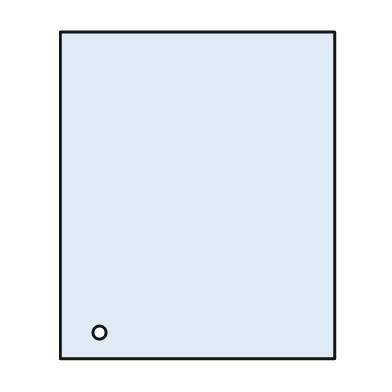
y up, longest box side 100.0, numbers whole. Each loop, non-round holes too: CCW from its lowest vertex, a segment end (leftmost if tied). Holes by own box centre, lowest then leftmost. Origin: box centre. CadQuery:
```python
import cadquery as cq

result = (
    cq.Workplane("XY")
    .moveTo(-42.0, -50.0)
    .lineTo(42.0, -50.0)
    .lineTo(42.0, 50.0)
    .lineTo(-42.0, 50.0)
    .close()
    .moveTo(-30.0, -42.0)
    .circle(2.0)
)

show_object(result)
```